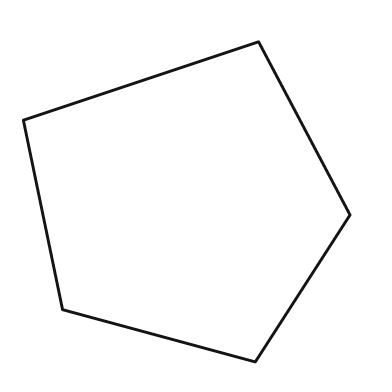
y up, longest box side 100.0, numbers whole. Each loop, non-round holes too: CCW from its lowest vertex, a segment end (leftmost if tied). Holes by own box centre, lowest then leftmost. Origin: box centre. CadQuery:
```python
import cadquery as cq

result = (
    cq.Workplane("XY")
    .moveTo(21.0, -49.0)
    .lineTo(50.0, -4.0)
    .lineTo(22.0, 49.0)
    .lineTo(-50.0, 25.0)
    .lineTo(-38.0, -33.0)
    .close()
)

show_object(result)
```